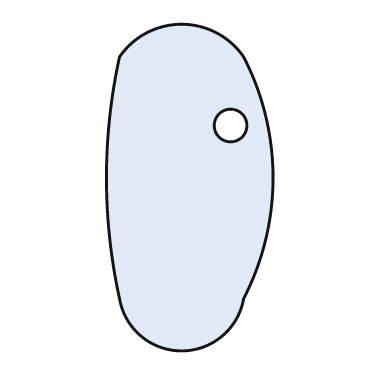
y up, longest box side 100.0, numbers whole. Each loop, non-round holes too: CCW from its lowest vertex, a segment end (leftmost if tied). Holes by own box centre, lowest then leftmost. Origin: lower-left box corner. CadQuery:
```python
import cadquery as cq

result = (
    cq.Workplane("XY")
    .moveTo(4.0, 16.0)
    .threePointArc((23.0, 0.0), (42.0, 16.0))
    .threePointArc((51.0, 53.0), (42.0, 90.0))
    .threePointArc((23.0, 100.0), (4.0, 90.0))
    .threePointArc((0.0, 53.0), (4.0, 16.0))
    .close()
    .moveTo(38.0, 69.0)
    .circle(5.0)
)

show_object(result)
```